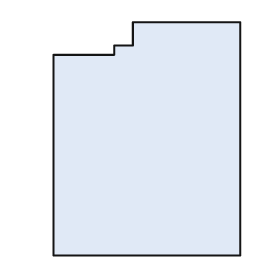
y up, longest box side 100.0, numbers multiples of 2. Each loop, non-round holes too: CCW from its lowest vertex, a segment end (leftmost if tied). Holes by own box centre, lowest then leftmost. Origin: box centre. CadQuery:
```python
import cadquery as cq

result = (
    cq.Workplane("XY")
    .moveTo(-40.0, -50.0)
    .lineTo(40.0, -50.0)
    .lineTo(40.0, 50.0)
    .lineTo(-6.0, 50.0)
    .lineTo(-6.0, 40.0)
    .lineTo(-14.0, 40.0)
    .lineTo(-14.0, 36.0)
    .lineTo(-40.0, 36.0)
    .close()
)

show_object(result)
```